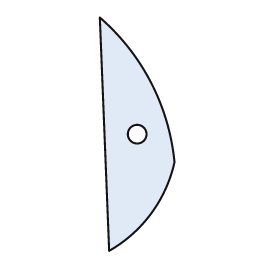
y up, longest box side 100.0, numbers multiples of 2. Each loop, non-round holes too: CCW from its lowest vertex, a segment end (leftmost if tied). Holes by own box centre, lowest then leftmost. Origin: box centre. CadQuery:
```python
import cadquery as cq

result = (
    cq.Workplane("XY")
    .moveTo(-12.0, -50.0)
    .threePointArc((6.0, -34.0), (16.0, -12.0))
    .threePointArc((6.0, 22.0), (-16.0, 50.0))
    .close()
    .moveTo(0.0, 0.0)
    .circle(4.0)
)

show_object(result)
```